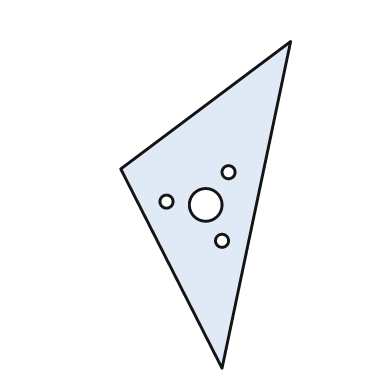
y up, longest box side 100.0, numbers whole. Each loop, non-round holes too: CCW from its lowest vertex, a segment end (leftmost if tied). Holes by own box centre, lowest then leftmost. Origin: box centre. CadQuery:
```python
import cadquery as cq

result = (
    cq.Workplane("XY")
    .moveTo(5.0, -50.0)
    .lineTo(26.0, 50.0)
    .lineTo(-26.0, 11.0)
    .close()
    .moveTo(5.0, -11.0)
    .circle(2.0)
    .moveTo(0.0, 0.0)
    .circle(5.0)
    .moveTo(-12.0, 1.0)
    .circle(2.0)
    .moveTo(7.0, 10.0)
    .circle(2.0)
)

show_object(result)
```